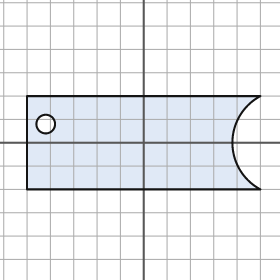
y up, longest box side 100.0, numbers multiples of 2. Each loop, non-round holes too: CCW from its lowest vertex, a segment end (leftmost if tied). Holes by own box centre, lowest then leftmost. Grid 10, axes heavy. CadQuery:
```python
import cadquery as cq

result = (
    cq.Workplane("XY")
    .moveTo(-50.0, -20.0)
    .lineTo(50.0, -20.0)
    .threePointArc((38.0, 0.0), (50.0, 20.0))
    .lineTo(-50.0, 20.0)
    .close()
    .moveTo(-42.0, 8.0)
    .circle(4.0)
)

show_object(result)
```